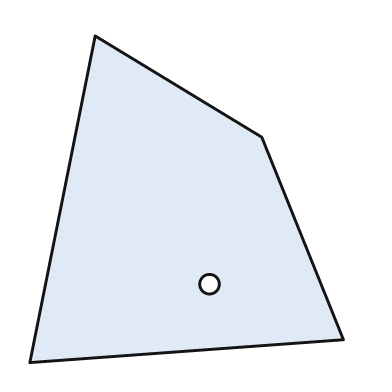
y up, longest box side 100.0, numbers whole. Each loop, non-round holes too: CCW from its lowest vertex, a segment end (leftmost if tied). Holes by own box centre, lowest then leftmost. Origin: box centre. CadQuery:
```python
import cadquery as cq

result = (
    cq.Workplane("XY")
    .moveTo(-48.0, -50.0)
    .lineTo(48.0, -43.0)
    .lineTo(23.0, 19.0)
    .lineTo(-28.0, 50.0)
    .close()
    .moveTo(7.0, -26.0)
    .circle(3.0)
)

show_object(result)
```